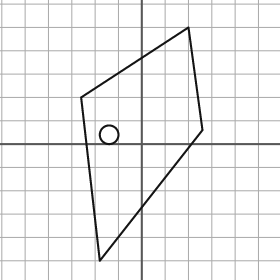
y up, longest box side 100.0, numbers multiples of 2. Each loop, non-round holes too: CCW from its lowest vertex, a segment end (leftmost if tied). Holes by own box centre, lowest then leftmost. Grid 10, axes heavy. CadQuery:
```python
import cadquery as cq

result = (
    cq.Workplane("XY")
    .moveTo(-18.0, -50.0)
    .lineTo(26.0, 6.0)
    .lineTo(20.0, 50.0)
    .lineTo(-26.0, 20.0)
    .close()
    .moveTo(-14.0, 4.0)
    .circle(4.0)
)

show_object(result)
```